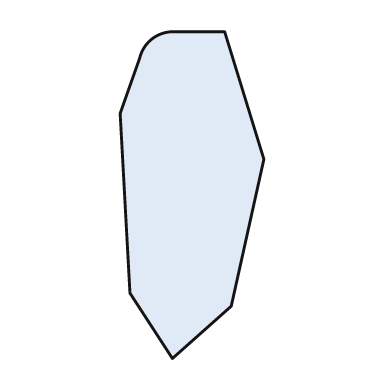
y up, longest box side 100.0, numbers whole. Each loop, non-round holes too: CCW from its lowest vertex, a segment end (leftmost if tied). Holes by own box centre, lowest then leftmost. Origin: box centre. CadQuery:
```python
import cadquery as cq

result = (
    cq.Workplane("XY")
    .moveTo(-6.0, -50.0)
    .lineTo(12.0, -34.0)
    .lineTo(22.0, 11.0)
    .lineTo(10.0, 50.0)
    .lineTo(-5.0, 50.0)
    .threePointArc((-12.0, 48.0), (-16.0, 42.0))
    .lineTo(-22.0, 25.0)
    .lineTo(-19.0, -30.0)
    .close()
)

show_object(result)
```